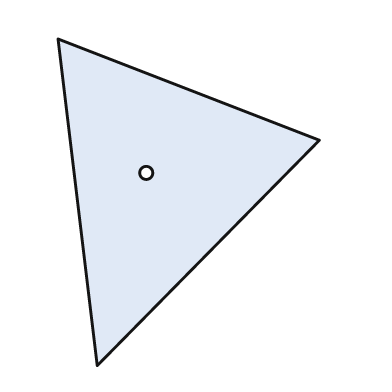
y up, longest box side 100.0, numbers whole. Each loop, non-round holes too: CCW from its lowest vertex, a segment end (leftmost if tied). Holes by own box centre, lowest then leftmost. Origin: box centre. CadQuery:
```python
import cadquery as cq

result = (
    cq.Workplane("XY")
    .moveTo(-28.0, -50.0)
    .lineTo(40.0, 19.0)
    .lineTo(-40.0, 50.0)
    .close()
    .moveTo(-13.0, 9.0)
    .circle(2.0)
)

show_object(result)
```